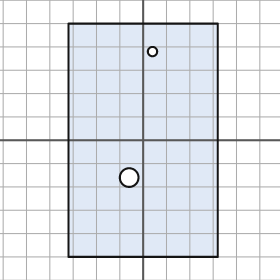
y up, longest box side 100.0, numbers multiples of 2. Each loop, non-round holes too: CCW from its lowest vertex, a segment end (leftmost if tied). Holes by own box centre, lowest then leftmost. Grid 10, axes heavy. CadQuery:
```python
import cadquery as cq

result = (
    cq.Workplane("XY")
    .moveTo(-32.0, -50.0)
    .lineTo(32.0, -50.0)
    .lineTo(32.0, 50.0)
    .lineTo(-32.0, 50.0)
    .close()
    .moveTo(-6.0, -16.0)
    .circle(4.0)
    .moveTo(4.0, 38.0)
    .circle(2.0)
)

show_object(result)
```